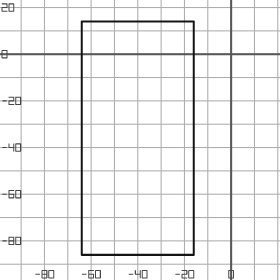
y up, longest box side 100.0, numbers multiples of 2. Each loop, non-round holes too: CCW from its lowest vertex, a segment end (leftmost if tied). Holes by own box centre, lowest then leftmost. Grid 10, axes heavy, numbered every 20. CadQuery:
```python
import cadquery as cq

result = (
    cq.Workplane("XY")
    .moveTo(-64.0, -86.0)
    .lineTo(-16.0, -86.0)
    .lineTo(-16.0, 14.0)
    .lineTo(-64.0, 14.0)
    .close()
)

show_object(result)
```